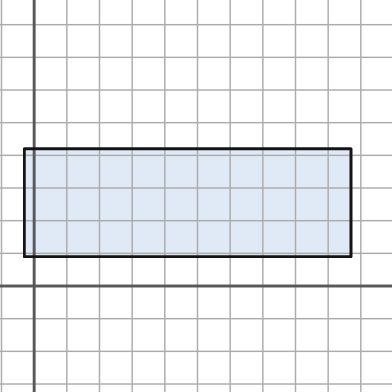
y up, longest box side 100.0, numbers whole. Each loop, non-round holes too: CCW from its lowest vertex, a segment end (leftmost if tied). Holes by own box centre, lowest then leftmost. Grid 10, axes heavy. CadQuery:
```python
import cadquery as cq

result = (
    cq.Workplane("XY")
    .moveTo(-3.0, 9.0)
    .lineTo(97.0, 9.0)
    .lineTo(97.0, 42.0)
    .lineTo(-3.0, 42.0)
    .close()
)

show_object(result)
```